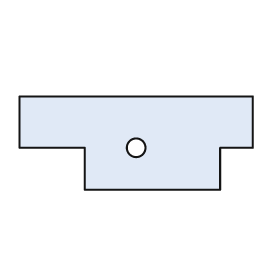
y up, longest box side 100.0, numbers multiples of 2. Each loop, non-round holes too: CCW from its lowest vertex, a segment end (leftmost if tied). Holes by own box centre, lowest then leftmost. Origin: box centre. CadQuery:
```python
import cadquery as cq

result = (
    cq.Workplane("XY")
    .moveTo(-22.0, -20.0)
    .lineTo(36.0, -20.0)
    .lineTo(36.0, -2.0)
    .lineTo(50.0, -2.0)
    .lineTo(50.0, 20.0)
    .lineTo(-50.0, 20.0)
    .lineTo(-50.0, -2.0)
    .lineTo(-22.0, -2.0)
    .close()
    .moveTo(0.0, -2.0)
    .circle(4.0)
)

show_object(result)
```